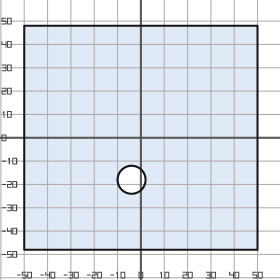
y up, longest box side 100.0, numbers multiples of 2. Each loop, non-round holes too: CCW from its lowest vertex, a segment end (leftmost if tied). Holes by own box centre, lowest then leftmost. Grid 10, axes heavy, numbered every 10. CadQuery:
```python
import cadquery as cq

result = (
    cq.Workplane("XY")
    .moveTo(-50.0, -48.0)
    .lineTo(50.0, -48.0)
    .lineTo(50.0, 48.0)
    .lineTo(-50.0, 48.0)
    .close()
    .moveTo(-4.0, -18.0)
    .circle(6.0)
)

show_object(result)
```